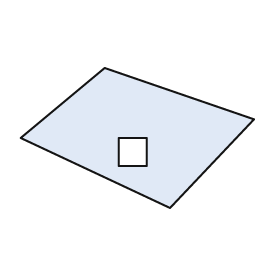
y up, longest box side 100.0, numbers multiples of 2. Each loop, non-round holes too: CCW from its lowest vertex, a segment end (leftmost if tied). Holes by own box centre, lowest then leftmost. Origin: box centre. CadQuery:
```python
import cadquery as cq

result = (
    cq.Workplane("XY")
    .moveTo(14.0, -30.0)
    .lineTo(50.0, 8.0)
    .lineTo(-14.0, 30.0)
    .lineTo(-50.0, 0.0)
    .close()
    .moveTo(-8.0, -12.0)
    .lineTo(4.0, -12.0)
    .lineTo(4.0, 0.0)
    .lineTo(-8.0, 0.0)
    .close()
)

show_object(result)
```